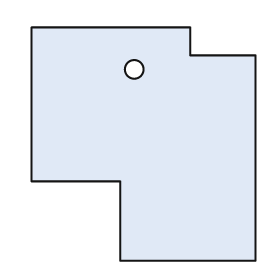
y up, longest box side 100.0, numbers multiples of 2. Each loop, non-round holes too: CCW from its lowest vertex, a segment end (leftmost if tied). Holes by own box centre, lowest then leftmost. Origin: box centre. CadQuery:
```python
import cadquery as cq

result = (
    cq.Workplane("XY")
    .moveTo(-10.0, -50.0)
    .lineTo(48.0, -50.0)
    .lineTo(48.0, 38.0)
    .lineTo(20.0, 38.0)
    .lineTo(20.0, 50.0)
    .lineTo(-48.0, 50.0)
    .lineTo(-48.0, -16.0)
    .lineTo(-10.0, -16.0)
    .close()
    .moveTo(-4.0, 32.0)
    .circle(4.0)
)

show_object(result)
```